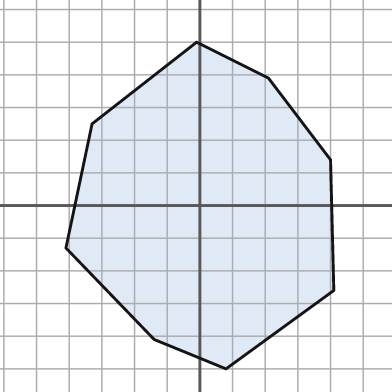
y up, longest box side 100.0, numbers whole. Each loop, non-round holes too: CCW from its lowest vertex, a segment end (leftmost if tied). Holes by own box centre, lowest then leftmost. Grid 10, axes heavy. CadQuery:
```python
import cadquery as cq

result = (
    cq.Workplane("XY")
    .moveTo(8.0, -50.0)
    .lineTo(41.0, -26.0)
    .lineTo(40.0, 14.0)
    .lineTo(21.0, 39.0)
    .lineTo(-1.0, 50.0)
    .lineTo(-33.0, 25.0)
    .lineTo(-41.0, -13.0)
    .lineTo(-14.0, -41.0)
    .close()
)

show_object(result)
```